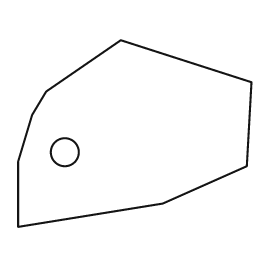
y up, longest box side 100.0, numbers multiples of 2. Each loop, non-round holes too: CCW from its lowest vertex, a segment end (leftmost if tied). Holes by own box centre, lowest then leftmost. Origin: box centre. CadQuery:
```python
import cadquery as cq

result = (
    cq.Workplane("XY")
    .moveTo(-50.0, -40.0)
    .lineTo(12.0, -30.0)
    .lineTo(48.0, -14.0)
    .lineTo(50.0, 22.0)
    .lineTo(-6.0, 40.0)
    .lineTo(-38.0, 18.0)
    .lineTo(-44.0, 8.0)
    .lineTo(-50.0, -12.0)
    .close()
    .moveTo(-30.0, -8.0)
    .circle(6.0)
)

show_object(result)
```